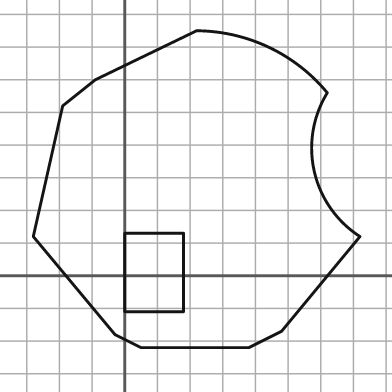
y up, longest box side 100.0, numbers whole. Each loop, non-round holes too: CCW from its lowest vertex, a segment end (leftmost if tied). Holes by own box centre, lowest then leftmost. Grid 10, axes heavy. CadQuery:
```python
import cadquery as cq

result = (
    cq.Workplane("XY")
    .moveTo(5.0, -22.0)
    .lineTo(38.0, -22.0)
    .lineTo(48.0, -17.0)
    .lineTo(72.0, 12.0)
    .threePointArc((58.0, 32.0), (62.0, 56.0))
    .threePointArc((44.0, 70.0), (22.0, 75.0))
    .lineTo(-9.0, 60.0)
    .lineTo(-19.0, 52.0)
    .lineTo(-28.0, 12.0)
    .lineTo(-3.0, -18.0)
    .close()
    .moveTo(0.0, -11.0)
    .lineTo(18.0, -11.0)
    .lineTo(18.0, 13.0)
    .lineTo(0.0, 13.0)
    .close()
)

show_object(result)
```